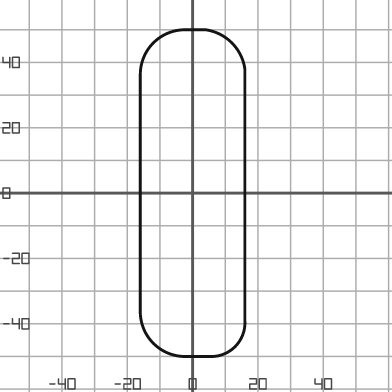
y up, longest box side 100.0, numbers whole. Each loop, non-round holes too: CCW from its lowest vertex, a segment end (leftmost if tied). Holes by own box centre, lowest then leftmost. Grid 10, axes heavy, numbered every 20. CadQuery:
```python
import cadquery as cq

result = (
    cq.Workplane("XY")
    .moveTo(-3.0, -50.0)
    .lineTo(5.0, -50.0)
    .threePointArc((13.0, -47.0), (16.0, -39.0))
    .lineTo(16.0, 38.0)
    .threePointArc((12.0, 46.0), (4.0, 50.0))
    .lineTo(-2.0, 50.0)
    .threePointArc((-12.0, 46.0), (-16.0, 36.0))
    .lineTo(-16.0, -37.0)
    .threePointArc((-12.0, -46.0), (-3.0, -50.0))
    .close()
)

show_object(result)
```